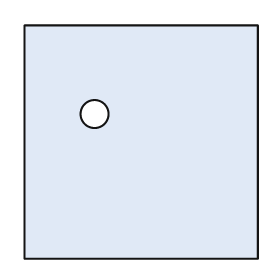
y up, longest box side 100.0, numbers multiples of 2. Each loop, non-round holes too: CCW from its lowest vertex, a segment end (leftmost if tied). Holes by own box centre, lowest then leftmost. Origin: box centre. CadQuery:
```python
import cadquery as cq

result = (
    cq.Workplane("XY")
    .moveTo(-50.0, -50.0)
    .lineTo(50.0, -50.0)
    .lineTo(50.0, 50.0)
    .lineTo(-50.0, 50.0)
    .close()
    .moveTo(-20.0, 12.0)
    .circle(6.0)
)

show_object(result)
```